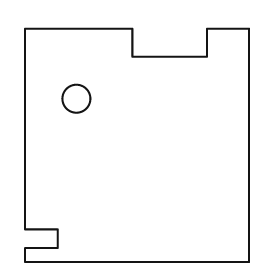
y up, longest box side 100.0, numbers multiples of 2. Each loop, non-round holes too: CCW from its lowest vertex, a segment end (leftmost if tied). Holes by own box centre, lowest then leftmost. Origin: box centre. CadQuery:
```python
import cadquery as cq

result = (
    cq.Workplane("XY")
    .moveTo(-48.0, -50.0)
    .lineTo(48.0, -50.0)
    .lineTo(48.0, 50.0)
    .lineTo(30.0, 50.0)
    .lineTo(30.0, 38.0)
    .lineTo(-2.0, 38.0)
    .lineTo(-2.0, 50.0)
    .lineTo(-48.0, 50.0)
    .lineTo(-48.0, -36.0)
    .lineTo(-34.0, -36.0)
    .lineTo(-34.0, -44.0)
    .lineTo(-48.0, -44.0)
    .close()
    .moveTo(-26.0, 20.0)
    .circle(6.0)
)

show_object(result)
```